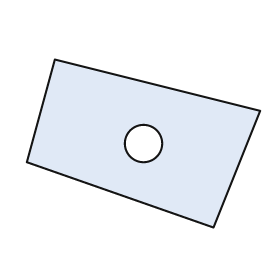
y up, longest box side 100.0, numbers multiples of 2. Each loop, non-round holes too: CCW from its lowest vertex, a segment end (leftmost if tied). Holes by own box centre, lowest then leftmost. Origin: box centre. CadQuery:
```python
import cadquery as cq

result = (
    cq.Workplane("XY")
    .moveTo(30.0, -36.0)
    .lineTo(50.0, 14.0)
    .lineTo(-38.0, 36.0)
    .lineTo(-50.0, -8.0)
    .close()
    .moveTo(0.0, 0.0)
    .circle(8.0)
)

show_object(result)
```